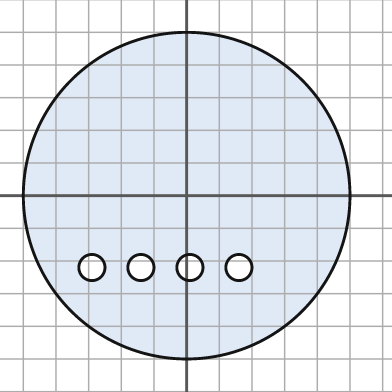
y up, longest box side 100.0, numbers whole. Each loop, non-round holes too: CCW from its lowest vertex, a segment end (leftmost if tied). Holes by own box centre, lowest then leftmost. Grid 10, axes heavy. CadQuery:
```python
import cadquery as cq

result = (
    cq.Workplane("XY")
    .moveTo(0.0, 0.0)
    .circle(50.0)
    .moveTo(-29.0, -22.0)
    .circle(4.0)
    .moveTo(-14.0, -22.0)
    .circle(4.0)
    .moveTo(1.0, -22.0)
    .circle(4.0)
    .moveTo(16.0, -22.0)
    .circle(4.0)
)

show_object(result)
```